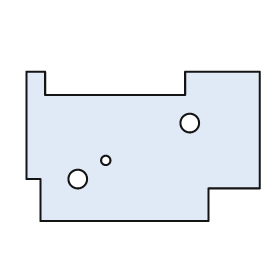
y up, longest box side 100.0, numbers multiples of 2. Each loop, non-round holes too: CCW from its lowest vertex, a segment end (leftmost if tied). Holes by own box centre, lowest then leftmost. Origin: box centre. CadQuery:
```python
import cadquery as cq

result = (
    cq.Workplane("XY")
    .moveTo(-44.0, -32.0)
    .lineTo(28.0, -32.0)
    .lineTo(28.0, -18.0)
    .lineTo(50.0, -18.0)
    .lineTo(50.0, 32.0)
    .lineTo(18.0, 32.0)
    .lineTo(18.0, 22.0)
    .lineTo(-42.0, 22.0)
    .lineTo(-42.0, 32.0)
    .lineTo(-50.0, 32.0)
    .lineTo(-50.0, -14.0)
    .lineTo(-44.0, -14.0)
    .close()
    .moveTo(-28.0, -14.0)
    .circle(4.0)
    .moveTo(-16.0, -6.0)
    .circle(2.0)
    .moveTo(20.0, 10.0)
    .circle(4.0)
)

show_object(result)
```